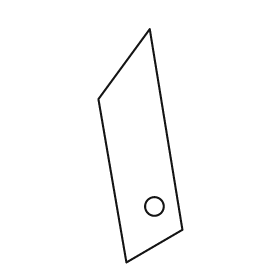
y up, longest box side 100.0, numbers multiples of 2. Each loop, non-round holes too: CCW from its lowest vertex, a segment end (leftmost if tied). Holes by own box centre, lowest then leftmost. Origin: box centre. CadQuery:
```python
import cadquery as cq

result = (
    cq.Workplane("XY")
    .moveTo(-6.0, -50.0)
    .lineTo(18.0, -36.0)
    .lineTo(4.0, 50.0)
    .lineTo(-18.0, 20.0)
    .close()
    .moveTo(6.0, -26.0)
    .circle(4.0)
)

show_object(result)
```